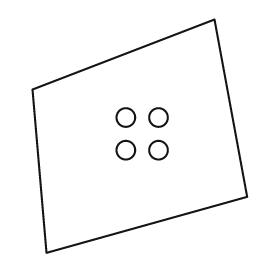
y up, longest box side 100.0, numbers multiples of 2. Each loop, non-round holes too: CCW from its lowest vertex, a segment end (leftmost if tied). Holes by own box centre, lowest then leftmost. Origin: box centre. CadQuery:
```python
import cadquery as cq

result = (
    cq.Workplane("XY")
    .moveTo(-40.0, -50.0)
    .lineTo(46.0, -26.0)
    .lineTo(32.0, 50.0)
    .lineTo(-46.0, 20.0)
    .close()
    .moveTo(-6.0, -6.0)
    .circle(4.0)
    .moveTo(8.0, -6.0)
    .circle(4.0)
    .moveTo(-6.0, 8.0)
    .circle(4.0)
    .moveTo(8.0, 8.0)
    .circle(4.0)
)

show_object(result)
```